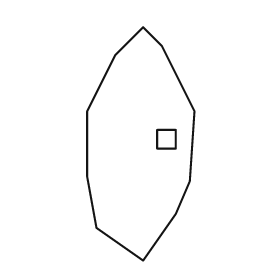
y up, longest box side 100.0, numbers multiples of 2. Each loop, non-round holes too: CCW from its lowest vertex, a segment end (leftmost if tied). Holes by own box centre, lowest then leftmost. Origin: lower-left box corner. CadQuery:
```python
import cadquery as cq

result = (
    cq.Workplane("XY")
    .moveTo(24.0, 0.0)
    .lineTo(38.0, 20.0)
    .lineTo(44.0, 34.0)
    .lineTo(46.0, 64.0)
    .lineTo(32.0, 92.0)
    .lineTo(24.0, 100.0)
    .lineTo(12.0, 88.0)
    .lineTo(0.0, 64.0)
    .lineTo(0.0, 36.0)
    .lineTo(4.0, 14.0)
    .close()
    .moveTo(30.0, 48.0)
    .lineTo(38.0, 48.0)
    .lineTo(38.0, 56.0)
    .lineTo(30.0, 56.0)
    .close()
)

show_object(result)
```